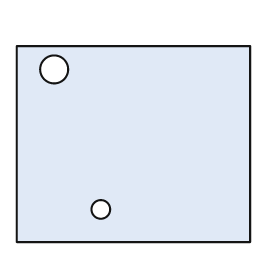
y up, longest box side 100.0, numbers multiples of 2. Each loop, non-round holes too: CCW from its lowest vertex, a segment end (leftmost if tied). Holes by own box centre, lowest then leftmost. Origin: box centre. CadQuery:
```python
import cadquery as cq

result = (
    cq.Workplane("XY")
    .moveTo(-50.0, -42.0)
    .lineTo(50.0, -42.0)
    .lineTo(50.0, 42.0)
    .lineTo(-50.0, 42.0)
    .close()
    .moveTo(-14.0, -28.0)
    .circle(4.0)
    .moveTo(-34.0, 32.0)
    .circle(6.0)
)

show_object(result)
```